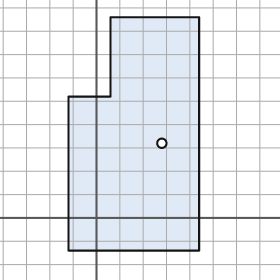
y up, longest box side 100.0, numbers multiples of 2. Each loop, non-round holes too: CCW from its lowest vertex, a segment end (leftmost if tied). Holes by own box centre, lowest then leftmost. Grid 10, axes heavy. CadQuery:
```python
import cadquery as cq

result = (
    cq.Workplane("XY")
    .moveTo(-12.0, -14.0)
    .lineTo(44.0, -14.0)
    .lineTo(44.0, 86.0)
    .lineTo(6.0, 86.0)
    .lineTo(6.0, 52.0)
    .lineTo(-12.0, 52.0)
    .close()
    .moveTo(28.0, 32.0)
    .circle(2.0)
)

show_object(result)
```